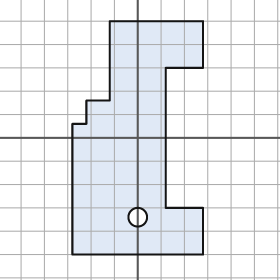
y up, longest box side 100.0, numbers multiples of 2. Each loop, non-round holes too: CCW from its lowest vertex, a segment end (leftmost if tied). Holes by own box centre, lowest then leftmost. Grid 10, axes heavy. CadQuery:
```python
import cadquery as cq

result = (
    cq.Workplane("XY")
    .moveTo(-28.0, -50.0)
    .lineTo(28.0, -50.0)
    .lineTo(28.0, -30.0)
    .lineTo(12.0, -30.0)
    .lineTo(12.0, 30.0)
    .lineTo(28.0, 30.0)
    .lineTo(28.0, 50.0)
    .lineTo(-12.0, 50.0)
    .lineTo(-12.0, 16.0)
    .lineTo(-22.0, 16.0)
    .lineTo(-22.0, 6.0)
    .lineTo(-28.0, 6.0)
    .close()
    .moveTo(0.0, -34.0)
    .circle(4.0)
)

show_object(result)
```